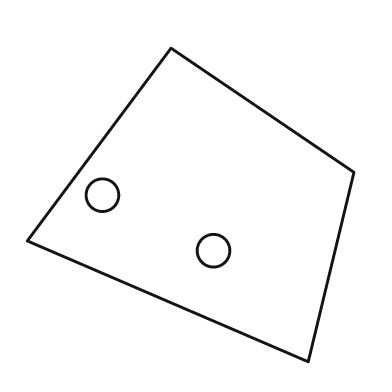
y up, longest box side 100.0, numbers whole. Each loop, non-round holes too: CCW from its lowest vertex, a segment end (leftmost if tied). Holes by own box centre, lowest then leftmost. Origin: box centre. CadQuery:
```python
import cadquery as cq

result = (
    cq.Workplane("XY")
    .moveTo(36.0, -48.0)
    .lineTo(50.0, 10.0)
    .lineTo(-6.0, 48.0)
    .lineTo(-50.0, -11.0)
    .close()
    .moveTo(7.0, -14.0)
    .circle(5.0)
    .moveTo(-27.0, 3.0)
    .circle(5.0)
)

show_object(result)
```